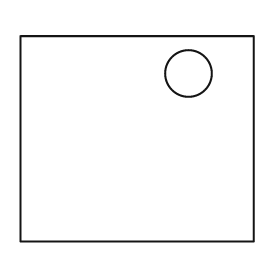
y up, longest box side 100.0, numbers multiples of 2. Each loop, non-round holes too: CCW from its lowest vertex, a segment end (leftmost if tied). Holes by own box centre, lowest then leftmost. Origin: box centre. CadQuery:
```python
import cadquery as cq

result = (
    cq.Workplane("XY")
    .moveTo(-50.0, -44.0)
    .lineTo(50.0, -44.0)
    .lineTo(50.0, 44.0)
    .lineTo(-50.0, 44.0)
    .close()
    .moveTo(22.0, 28.0)
    .circle(10.0)
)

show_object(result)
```